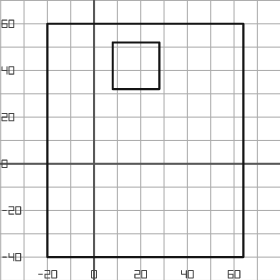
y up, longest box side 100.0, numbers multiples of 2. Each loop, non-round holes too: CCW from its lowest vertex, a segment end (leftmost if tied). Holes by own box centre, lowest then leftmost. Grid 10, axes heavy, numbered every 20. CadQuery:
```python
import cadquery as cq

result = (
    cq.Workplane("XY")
    .moveTo(-20.0, -40.0)
    .lineTo(64.0, -40.0)
    .lineTo(64.0, 60.0)
    .lineTo(-20.0, 60.0)
    .close()
    .moveTo(8.0, 32.0)
    .lineTo(28.0, 32.0)
    .lineTo(28.0, 52.0)
    .lineTo(8.0, 52.0)
    .close()
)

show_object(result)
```